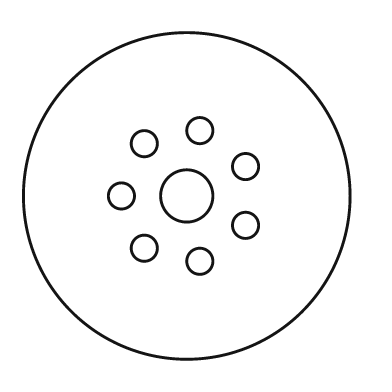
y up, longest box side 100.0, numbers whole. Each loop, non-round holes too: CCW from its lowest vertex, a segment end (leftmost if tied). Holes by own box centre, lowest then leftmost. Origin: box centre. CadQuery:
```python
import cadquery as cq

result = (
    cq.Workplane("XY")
    .moveTo(0.0, 0.0)
    .circle(50.0)
    .moveTo(4.0, -20.0)
    .circle(4.0)
    .moveTo(-13.0, -16.0)
    .circle(4.0)
    .moveTo(18.0, -9.0)
    .circle(4.0)
    .moveTo(-20.0, 0.0)
    .circle(4.0)
    .moveTo(0.0, 0.0)
    .circle(8.0)
    .moveTo(18.0, 9.0)
    .circle(4.0)
    .moveTo(-13.0, 16.0)
    .circle(4.0)
    .moveTo(4.0, 20.0)
    .circle(4.0)
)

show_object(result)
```